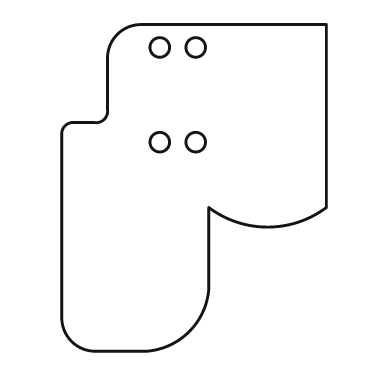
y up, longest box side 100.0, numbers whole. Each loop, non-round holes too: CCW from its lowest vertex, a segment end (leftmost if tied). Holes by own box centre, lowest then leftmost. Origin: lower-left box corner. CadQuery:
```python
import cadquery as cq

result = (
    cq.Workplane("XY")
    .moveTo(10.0, 0.0)
    .lineTo(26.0, 0.0)
    .threePointArc((39.0, 6.0), (45.0, 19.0))
    .lineTo(45.0, 44.0)
    .threePointArc((63.0, 38.0), (81.0, 44.0))
    .lineTo(81.0, 100.0)
    .lineTo(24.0, 100.0)
    .threePointArc((17.0, 97.0), (14.0, 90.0))
    .lineTo(14.0, 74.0)
    .threePointArc((13.0, 71.0), (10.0, 70.0))
    .lineTo(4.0, 70.0)
    .threePointArc((1.0, 69.0), (0.0, 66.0))
    .lineTo(0.0, 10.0)
    .threePointArc((3.0, 3.0), (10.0, 0.0))
    .close()
    .moveTo(30.0, 64.0)
    .circle(3.0)
    .moveTo(41.0, 64.0)
    .circle(3.0)
    .moveTo(30.0, 93.0)
    .circle(3.0)
    .moveTo(41.0, 93.0)
    .circle(3.0)
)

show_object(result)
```